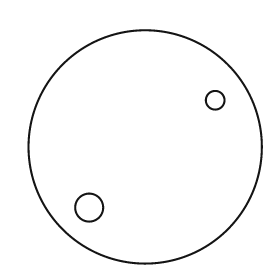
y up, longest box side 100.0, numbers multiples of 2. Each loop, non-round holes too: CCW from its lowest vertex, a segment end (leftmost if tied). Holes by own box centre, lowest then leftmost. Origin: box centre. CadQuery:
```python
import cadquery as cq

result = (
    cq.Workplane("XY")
    .moveTo(0.0, 0.0)
    .circle(50.0)
    .moveTo(-24.0, -26.0)
    .circle(6.0)
    .moveTo(30.0, 20.0)
    .circle(4.0)
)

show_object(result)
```